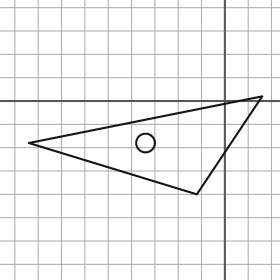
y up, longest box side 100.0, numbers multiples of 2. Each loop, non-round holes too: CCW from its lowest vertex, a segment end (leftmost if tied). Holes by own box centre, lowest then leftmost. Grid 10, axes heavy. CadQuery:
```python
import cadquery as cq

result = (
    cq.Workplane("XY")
    .moveTo(-12.0, -40.0)
    .lineTo(16.0, 2.0)
    .lineTo(-84.0, -18.0)
    .close()
    .moveTo(-34.0, -18.0)
    .circle(4.0)
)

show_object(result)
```